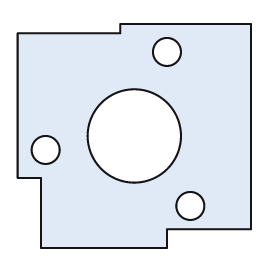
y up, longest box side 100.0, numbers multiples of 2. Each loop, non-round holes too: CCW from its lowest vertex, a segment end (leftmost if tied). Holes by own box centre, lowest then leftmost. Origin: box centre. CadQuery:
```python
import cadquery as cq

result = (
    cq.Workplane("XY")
    .moveTo(-40.0, -48.0)
    .lineTo(14.0, -48.0)
    .lineTo(14.0, -40.0)
    .lineTo(50.0, -40.0)
    .lineTo(50.0, 48.0)
    .lineTo(-6.0, 48.0)
    .lineTo(-6.0, 44.0)
    .lineTo(-50.0, 44.0)
    .lineTo(-50.0, -18.0)
    .lineTo(-40.0, -18.0)
    .close()
    .moveTo(24.0, -30.0)
    .circle(6.0)
    .moveTo(-38.0, -6.0)
    .circle(6.0)
    .moveTo(0.0, 0.0)
    .circle(20.0)
    .moveTo(14.0, 36.0)
    .circle(6.0)
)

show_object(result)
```